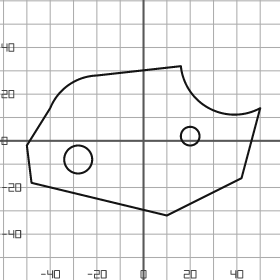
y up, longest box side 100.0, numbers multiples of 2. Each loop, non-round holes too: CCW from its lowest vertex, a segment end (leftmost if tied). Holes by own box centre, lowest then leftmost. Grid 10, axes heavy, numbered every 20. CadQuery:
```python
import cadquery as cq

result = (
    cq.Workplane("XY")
    .moveTo(10.0, -32.0)
    .lineTo(42.0, -16.0)
    .lineTo(50.0, 14.0)
    .threePointArc((28.0, 14.0), (16.0, 32.0))
    .lineTo(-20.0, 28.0)
    .threePointArc((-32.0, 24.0), (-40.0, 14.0))
    .lineTo(-50.0, -2.0)
    .lineTo(-48.0, -18.0)
    .close()
    .moveTo(-28.0, -8.0)
    .circle(6.0)
    .moveTo(20.0, 2.0)
    .circle(4.0)
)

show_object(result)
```